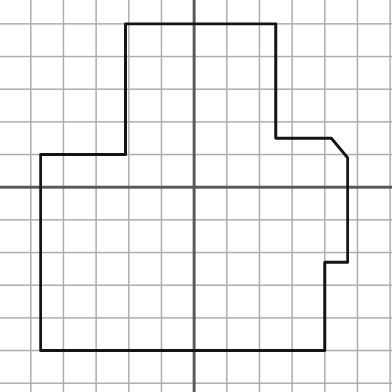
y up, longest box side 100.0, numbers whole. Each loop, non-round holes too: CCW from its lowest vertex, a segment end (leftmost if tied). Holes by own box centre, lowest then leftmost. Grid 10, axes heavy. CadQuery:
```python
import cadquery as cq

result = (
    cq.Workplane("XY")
    .moveTo(-47.0, -50.0)
    .lineTo(40.0, -50.0)
    .lineTo(40.0, -23.0)
    .lineTo(47.0, -23.0)
    .lineTo(47.0, 9.0)
    .lineTo(42.0, 15.0)
    .lineTo(25.0, 15.0)
    .lineTo(25.0, 50.0)
    .lineTo(-21.0, 50.0)
    .lineTo(-21.0, 10.0)
    .lineTo(-47.0, 10.0)
    .close()
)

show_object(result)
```